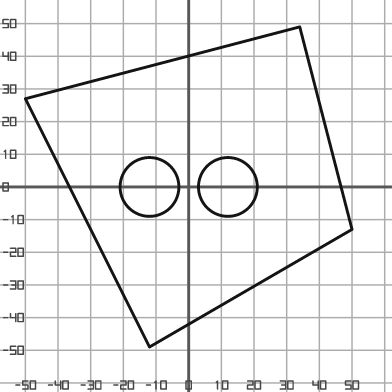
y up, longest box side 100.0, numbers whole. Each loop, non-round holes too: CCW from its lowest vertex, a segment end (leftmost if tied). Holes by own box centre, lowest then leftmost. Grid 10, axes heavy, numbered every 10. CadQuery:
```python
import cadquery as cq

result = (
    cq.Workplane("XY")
    .moveTo(-12.0, -49.0)
    .lineTo(50.0, -13.0)
    .lineTo(34.0, 49.0)
    .lineTo(-50.0, 27.0)
    .close()
    .moveTo(-12.0, 0.0)
    .circle(9.0)
    .moveTo(12.0, 0.0)
    .circle(9.0)
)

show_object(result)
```